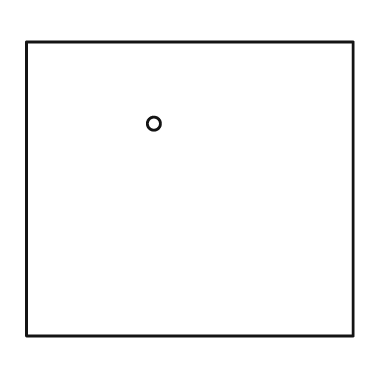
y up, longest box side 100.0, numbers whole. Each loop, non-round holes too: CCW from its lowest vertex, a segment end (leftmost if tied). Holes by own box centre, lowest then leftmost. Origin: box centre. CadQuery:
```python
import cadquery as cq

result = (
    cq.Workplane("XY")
    .moveTo(-50.0, -45.0)
    .lineTo(50.0, -45.0)
    .lineTo(50.0, 45.0)
    .lineTo(-50.0, 45.0)
    .close()
    .moveTo(-11.0, 20.0)
    .circle(2.0)
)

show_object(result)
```